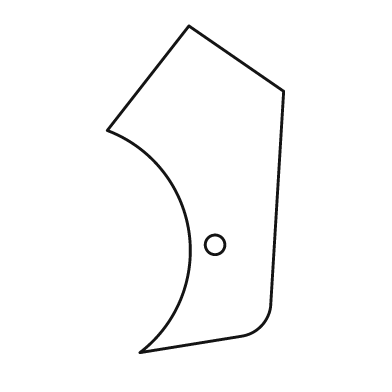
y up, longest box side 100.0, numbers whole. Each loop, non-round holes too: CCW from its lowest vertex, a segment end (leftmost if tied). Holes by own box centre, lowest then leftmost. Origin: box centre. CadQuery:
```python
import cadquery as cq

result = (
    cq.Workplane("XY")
    .moveTo(-17.0, -50.0)
    .lineTo(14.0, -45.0)
    .threePointArc((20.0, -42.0), (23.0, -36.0))
    .lineTo(27.0, 30.0)
    .lineTo(-2.0, 50.0)
    .lineTo(-27.0, 18.0)
    .threePointArc((-2.0, -13.0), (-17.0, -50.0))
    .close()
    .moveTo(6.0, -17.0)
    .circle(3.0)
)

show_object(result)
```